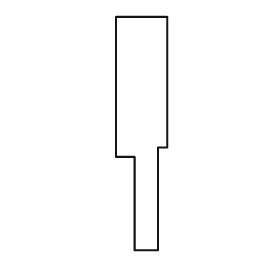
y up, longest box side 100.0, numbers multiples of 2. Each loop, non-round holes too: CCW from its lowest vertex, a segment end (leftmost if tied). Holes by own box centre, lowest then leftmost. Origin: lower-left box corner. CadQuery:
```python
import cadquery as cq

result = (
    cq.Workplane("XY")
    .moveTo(8.0, 0.0)
    .lineTo(18.0, 0.0)
    .lineTo(18.0, 44.0)
    .lineTo(22.0, 44.0)
    .lineTo(22.0, 100.0)
    .lineTo(0.0, 100.0)
    .lineTo(0.0, 40.0)
    .lineTo(8.0, 40.0)
    .close()
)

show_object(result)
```